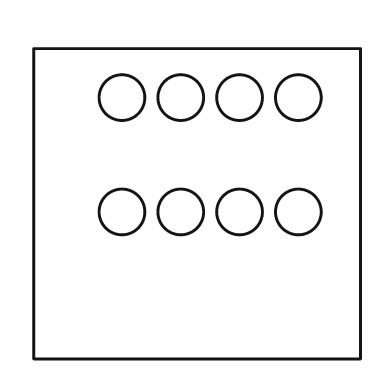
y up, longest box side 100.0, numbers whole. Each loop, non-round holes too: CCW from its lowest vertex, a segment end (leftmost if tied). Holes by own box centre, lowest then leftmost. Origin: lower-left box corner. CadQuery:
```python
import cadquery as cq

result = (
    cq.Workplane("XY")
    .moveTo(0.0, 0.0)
    .lineTo(100.0, 0.0)
    .lineTo(100.0, 95.0)
    .lineTo(0.0, 95.0)
    .close()
    .moveTo(27.0, 45.0)
    .circle(7.0)
    .moveTo(45.0, 45.0)
    .circle(7.0)
    .moveTo(63.0, 45.0)
    .circle(7.0)
    .moveTo(81.0, 45.0)
    .circle(7.0)
    .moveTo(27.0, 80.0)
    .circle(7.0)
    .moveTo(45.0, 80.0)
    .circle(7.0)
    .moveTo(63.0, 80.0)
    .circle(7.0)
    .moveTo(81.0, 80.0)
    .circle(7.0)
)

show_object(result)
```